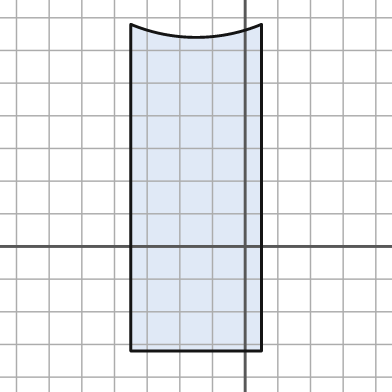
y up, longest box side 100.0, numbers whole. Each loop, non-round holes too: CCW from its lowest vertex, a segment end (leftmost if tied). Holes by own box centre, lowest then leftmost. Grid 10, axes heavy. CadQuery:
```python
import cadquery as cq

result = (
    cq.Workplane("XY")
    .moveTo(-35.0, -32.0)
    .lineTo(5.0, -32.0)
    .lineTo(5.0, 68.0)
    .threePointArc((-15.0, 64.0), (-35.0, 68.0))
    .close()
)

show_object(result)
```